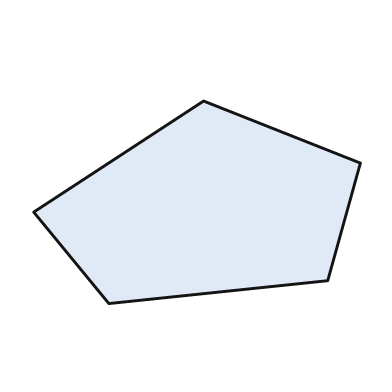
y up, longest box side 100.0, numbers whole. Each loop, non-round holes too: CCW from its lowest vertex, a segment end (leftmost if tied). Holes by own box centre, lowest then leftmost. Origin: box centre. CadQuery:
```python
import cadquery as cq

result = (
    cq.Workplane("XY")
    .moveTo(-27.0, -31.0)
    .lineTo(40.0, -24.0)
    .lineTo(50.0, 12.0)
    .lineTo(2.0, 31.0)
    .lineTo(-50.0, -3.0)
    .close()
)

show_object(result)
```